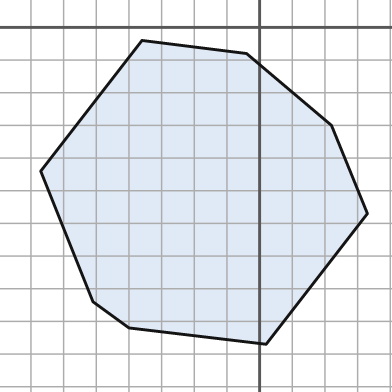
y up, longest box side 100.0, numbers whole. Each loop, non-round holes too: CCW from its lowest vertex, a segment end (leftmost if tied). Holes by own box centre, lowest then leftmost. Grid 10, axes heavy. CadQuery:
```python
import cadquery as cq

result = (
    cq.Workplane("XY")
    .moveTo(2.0, -97.0)
    .lineTo(33.0, -57.0)
    .lineTo(22.0, -30.0)
    .lineTo(-4.0, -8.0)
    .lineTo(-36.0, -4.0)
    .lineTo(-67.0, -44.0)
    .lineTo(-51.0, -84.0)
    .lineTo(-40.0, -92.0)
    .close()
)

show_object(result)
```